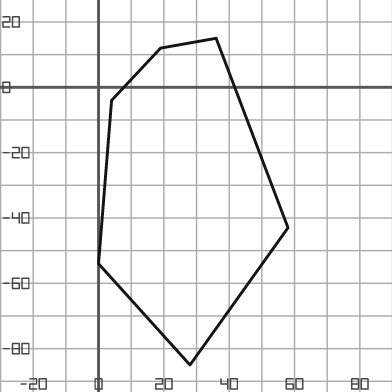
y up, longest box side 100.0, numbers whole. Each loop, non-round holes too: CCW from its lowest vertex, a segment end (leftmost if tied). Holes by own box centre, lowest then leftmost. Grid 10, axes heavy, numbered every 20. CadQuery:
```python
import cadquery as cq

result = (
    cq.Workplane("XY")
    .moveTo(28.0, -85.0)
    .lineTo(58.0, -43.0)
    .lineTo(36.0, 15.0)
    .lineTo(19.0, 12.0)
    .lineTo(4.0, -4.0)
    .lineTo(0.0, -54.0)
    .close()
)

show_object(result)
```